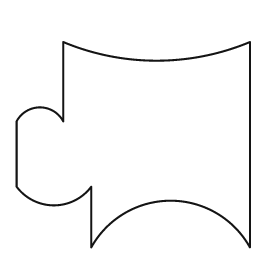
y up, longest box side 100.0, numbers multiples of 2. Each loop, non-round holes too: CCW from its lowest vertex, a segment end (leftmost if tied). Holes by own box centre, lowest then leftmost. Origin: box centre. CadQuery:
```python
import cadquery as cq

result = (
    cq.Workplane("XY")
    .moveTo(-18.0, -44.0)
    .threePointArc((16.0, -24.0), (50.0, -44.0))
    .lineTo(50.0, 44.0)
    .threePointArc((10.0, 36.0), (-30.0, 44.0))
    .lineTo(-30.0, 10.0)
    .threePointArc((-40.0, 16.0), (-50.0, 10.0))
    .lineTo(-50.0, -18.0)
    .threePointArc((-34.0, -26.0), (-18.0, -18.0))
    .close()
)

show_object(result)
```